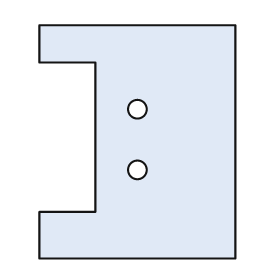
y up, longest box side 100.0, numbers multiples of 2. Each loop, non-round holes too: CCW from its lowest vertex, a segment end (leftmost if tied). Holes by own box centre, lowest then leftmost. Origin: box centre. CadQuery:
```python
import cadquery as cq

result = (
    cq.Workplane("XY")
    .moveTo(-42.0, -50.0)
    .lineTo(42.0, -50.0)
    .lineTo(42.0, 50.0)
    .lineTo(-42.0, 50.0)
    .lineTo(-42.0, 34.0)
    .lineTo(-18.0, 34.0)
    .lineTo(-18.0, -30.0)
    .lineTo(-42.0, -30.0)
    .close()
    .moveTo(0.0, -12.0)
    .circle(4.0)
    .moveTo(0.0, 14.0)
    .circle(4.0)
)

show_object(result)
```